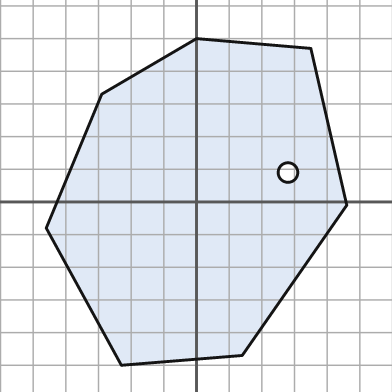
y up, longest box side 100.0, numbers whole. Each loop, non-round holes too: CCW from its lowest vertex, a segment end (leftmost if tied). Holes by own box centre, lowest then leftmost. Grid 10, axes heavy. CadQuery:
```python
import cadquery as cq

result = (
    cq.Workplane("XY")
    .moveTo(-23.0, -50.0)
    .lineTo(14.0, -47.0)
    .lineTo(46.0, -1.0)
    .lineTo(35.0, 47.0)
    .lineTo(0.0, 50.0)
    .lineTo(-29.0, 33.0)
    .lineTo(-46.0, -8.0)
    .close()
    .moveTo(28.0, 9.0)
    .circle(3.0)
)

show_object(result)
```